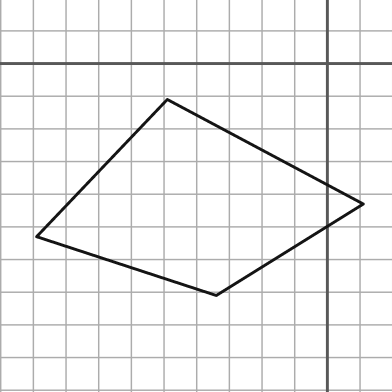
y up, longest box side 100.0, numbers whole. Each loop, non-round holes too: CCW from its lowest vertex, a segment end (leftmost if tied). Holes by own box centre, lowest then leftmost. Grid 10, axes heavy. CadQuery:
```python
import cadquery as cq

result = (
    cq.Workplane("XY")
    .moveTo(-34.0, -71.0)
    .lineTo(11.0, -43.0)
    .lineTo(-49.0, -11.0)
    .lineTo(-89.0, -53.0)
    .close()
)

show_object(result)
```